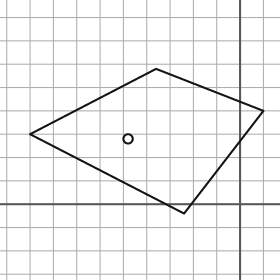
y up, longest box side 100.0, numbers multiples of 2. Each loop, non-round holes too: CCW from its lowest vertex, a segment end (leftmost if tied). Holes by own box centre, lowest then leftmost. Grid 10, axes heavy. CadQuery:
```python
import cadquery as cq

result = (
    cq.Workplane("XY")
    .moveTo(-24.0, -4.0)
    .lineTo(10.0, 40.0)
    .lineTo(-36.0, 58.0)
    .lineTo(-90.0, 30.0)
    .close()
    .moveTo(-48.0, 28.0)
    .circle(2.0)
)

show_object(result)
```